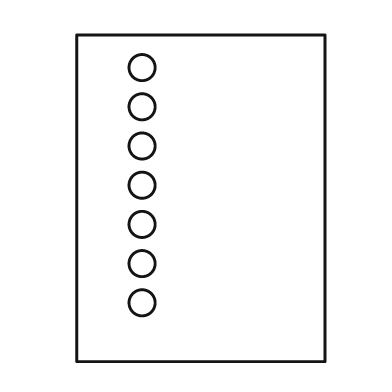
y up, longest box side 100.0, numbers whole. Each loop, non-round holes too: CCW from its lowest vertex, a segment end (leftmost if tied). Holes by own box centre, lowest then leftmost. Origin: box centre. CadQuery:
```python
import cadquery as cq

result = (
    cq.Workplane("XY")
    .moveTo(-38.0, -50.0)
    .lineTo(38.0, -50.0)
    .lineTo(38.0, 50.0)
    .lineTo(-38.0, 50.0)
    .close()
    .moveTo(-18.0, -32.0)
    .circle(4.0)
    .moveTo(-18.0, -20.0)
    .circle(4.0)
    .moveTo(-18.0, -8.0)
    .circle(4.0)
    .moveTo(-18.0, 4.0)
    .circle(4.0)
    .moveTo(-18.0, 16.0)
    .circle(4.0)
    .moveTo(-18.0, 28.0)
    .circle(4.0)
    .moveTo(-18.0, 40.0)
    .circle(4.0)
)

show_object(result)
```